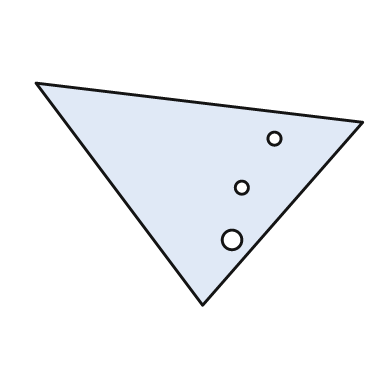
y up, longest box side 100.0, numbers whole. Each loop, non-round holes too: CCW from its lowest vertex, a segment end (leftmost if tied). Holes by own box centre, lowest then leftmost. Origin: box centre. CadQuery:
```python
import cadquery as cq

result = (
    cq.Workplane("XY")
    .moveTo(1.0, -34.0)
    .lineTo(50.0, 22.0)
    .lineTo(-50.0, 34.0)
    .close()
    .moveTo(10.0, -14.0)
    .circle(3.0)
    .moveTo(13.0, 2.0)
    .circle(2.0)
    .moveTo(23.0, 17.0)
    .circle(2.0)
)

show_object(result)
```